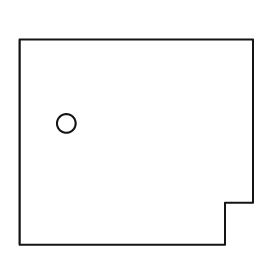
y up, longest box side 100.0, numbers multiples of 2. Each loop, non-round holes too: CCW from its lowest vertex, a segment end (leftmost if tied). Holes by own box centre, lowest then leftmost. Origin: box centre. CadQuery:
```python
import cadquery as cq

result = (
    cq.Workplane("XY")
    .moveTo(-50.0, -44.0)
    .lineTo(38.0, -44.0)
    .lineTo(38.0, -26.0)
    .lineTo(50.0, -26.0)
    .lineTo(50.0, 44.0)
    .lineTo(-50.0, 44.0)
    .close()
    .moveTo(-30.0, 8.0)
    .circle(4.0)
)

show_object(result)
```